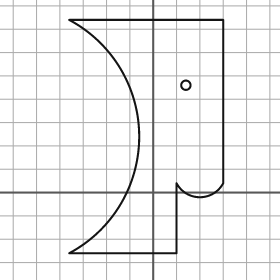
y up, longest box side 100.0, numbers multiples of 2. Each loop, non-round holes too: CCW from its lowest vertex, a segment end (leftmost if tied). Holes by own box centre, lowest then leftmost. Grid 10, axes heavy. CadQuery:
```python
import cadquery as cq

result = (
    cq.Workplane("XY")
    .moveTo(-36.0, -26.0)
    .lineTo(10.0, -26.0)
    .lineTo(10.0, 4.0)
    .threePointArc((20.0, -2.0), (30.0, 4.0))
    .lineTo(30.0, 74.0)
    .lineTo(-36.0, 74.0)
    .threePointArc((-6.0, 24.0), (-36.0, -26.0))
    .close()
    .moveTo(14.0, 46.0)
    .circle(2.0)
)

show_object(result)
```